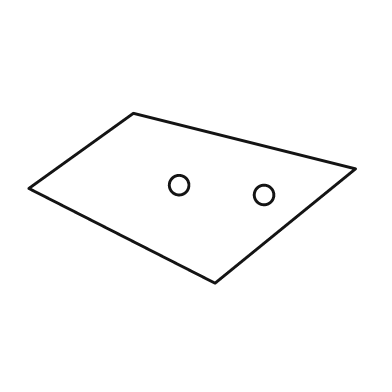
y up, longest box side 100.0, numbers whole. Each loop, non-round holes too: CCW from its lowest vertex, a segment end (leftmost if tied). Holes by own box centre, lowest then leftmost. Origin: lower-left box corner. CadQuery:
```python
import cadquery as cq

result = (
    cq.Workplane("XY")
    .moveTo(57.0, 0.0)
    .lineTo(100.0, 35.0)
    .lineTo(32.0, 52.0)
    .lineTo(0.0, 29.0)
    .close()
    .moveTo(72.0, 27.0)
    .circle(3.0)
    .moveTo(46.0, 30.0)
    .circle(3.0)
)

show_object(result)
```